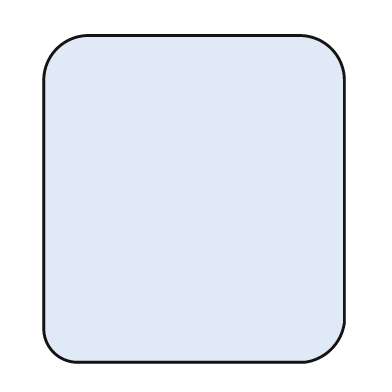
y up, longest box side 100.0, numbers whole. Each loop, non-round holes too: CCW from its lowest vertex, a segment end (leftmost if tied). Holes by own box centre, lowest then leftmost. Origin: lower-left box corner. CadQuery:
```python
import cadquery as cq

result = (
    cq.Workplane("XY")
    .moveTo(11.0, 0.0)
    .lineTo(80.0, 0.0)
    .threePointArc((88.0, 4.0), (92.0, 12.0))
    .lineTo(92.0, 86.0)
    .threePointArc((88.0, 96.0), (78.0, 100.0))
    .lineTo(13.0, 100.0)
    .threePointArc((4.0, 96.0), (0.0, 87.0))
    .lineTo(0.0, 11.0)
    .threePointArc((3.0, 3.0), (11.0, 0.0))
    .close()
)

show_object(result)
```